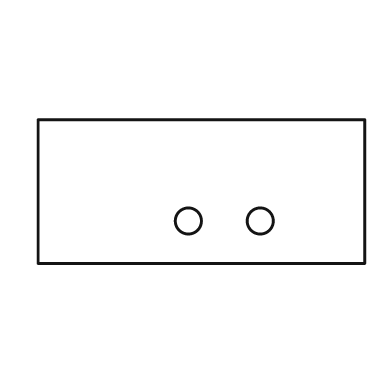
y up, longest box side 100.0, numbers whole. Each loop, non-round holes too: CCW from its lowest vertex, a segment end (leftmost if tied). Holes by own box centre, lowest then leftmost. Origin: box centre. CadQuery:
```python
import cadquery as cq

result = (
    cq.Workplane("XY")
    .moveTo(-50.0, -22.0)
    .lineTo(50.0, -22.0)
    .lineTo(50.0, 22.0)
    .lineTo(-50.0, 22.0)
    .close()
    .moveTo(-4.0, -9.0)
    .circle(4.0)
    .moveTo(18.0, -9.0)
    .circle(4.0)
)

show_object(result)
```